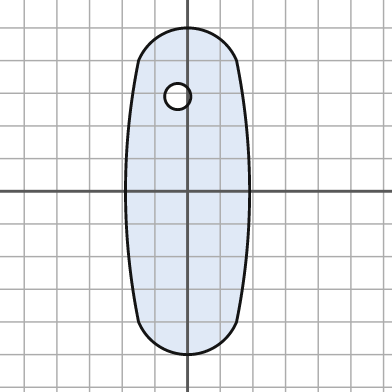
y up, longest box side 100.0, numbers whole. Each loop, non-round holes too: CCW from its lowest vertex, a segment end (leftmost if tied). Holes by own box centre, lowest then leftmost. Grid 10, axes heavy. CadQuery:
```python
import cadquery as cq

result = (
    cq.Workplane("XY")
    .moveTo(-15.0, -40.0)
    .threePointArc((0.0, -50.0), (15.0, -40.0))
    .threePointArc((19.0, 0.0), (15.0, 40.0))
    .threePointArc((0.0, 50.0), (-15.0, 40.0))
    .threePointArc((-19.0, 0.0), (-15.0, -40.0))
    .close()
    .moveTo(-3.0, 29.0)
    .circle(4.0)
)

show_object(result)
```